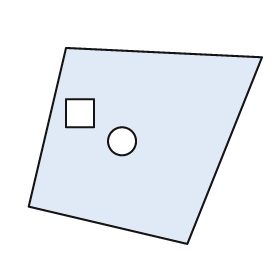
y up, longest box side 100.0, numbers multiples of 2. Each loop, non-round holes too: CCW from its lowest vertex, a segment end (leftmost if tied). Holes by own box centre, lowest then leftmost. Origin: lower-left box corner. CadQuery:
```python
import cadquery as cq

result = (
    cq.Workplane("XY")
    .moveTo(68.0, 0.0)
    .lineTo(100.0, 80.0)
    .lineTo(16.0, 84.0)
    .lineTo(0.0, 16.0)
    .close()
    .moveTo(40.0, 44.0)
    .circle(6.0)
    .moveTo(16.0, 50.0)
    .lineTo(28.0, 50.0)
    .lineTo(28.0, 62.0)
    .lineTo(16.0, 62.0)
    .close()
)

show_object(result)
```